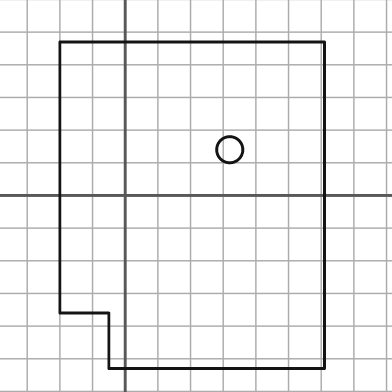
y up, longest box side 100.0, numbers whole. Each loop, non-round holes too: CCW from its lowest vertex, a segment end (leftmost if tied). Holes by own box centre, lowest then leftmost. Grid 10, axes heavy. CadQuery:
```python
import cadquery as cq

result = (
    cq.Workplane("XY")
    .moveTo(-5.0, -53.0)
    .lineTo(61.0, -53.0)
    .lineTo(61.0, 47.0)
    .lineTo(-20.0, 47.0)
    .lineTo(-20.0, -36.0)
    .lineTo(-5.0, -36.0)
    .close()
    .moveTo(32.0, 14.0)
    .circle(4.0)
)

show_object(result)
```